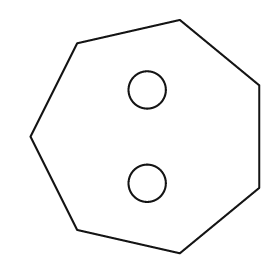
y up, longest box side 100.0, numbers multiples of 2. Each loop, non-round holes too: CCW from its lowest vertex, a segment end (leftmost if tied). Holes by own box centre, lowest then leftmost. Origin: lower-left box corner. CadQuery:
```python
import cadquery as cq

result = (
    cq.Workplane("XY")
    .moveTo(64.0, 0.0)
    .lineTo(98.0, 28.0)
    .lineTo(98.0, 72.0)
    .lineTo(64.0, 100.0)
    .lineTo(20.0, 90.0)
    .lineTo(0.0, 50.0)
    .lineTo(20.0, 10.0)
    .close()
    .moveTo(50.0, 30.0)
    .circle(8.0)
    .moveTo(50.0, 70.0)
    .circle(8.0)
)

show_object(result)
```